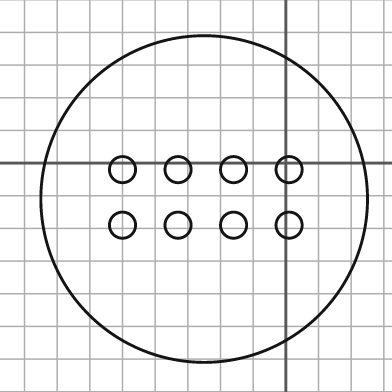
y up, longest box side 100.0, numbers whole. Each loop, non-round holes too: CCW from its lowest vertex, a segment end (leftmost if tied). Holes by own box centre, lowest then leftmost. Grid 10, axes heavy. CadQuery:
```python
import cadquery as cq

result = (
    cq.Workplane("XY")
    .moveTo(-25.0, -11.0)
    .circle(50.0)
    .moveTo(-50.0, -19.0)
    .circle(4.0)
    .moveTo(-33.0, -19.0)
    .circle(4.0)
    .moveTo(-16.0, -19.0)
    .circle(4.0)
    .moveTo(1.0, -19.0)
    .circle(4.0)
    .moveTo(-50.0, -2.0)
    .circle(4.0)
    .moveTo(-33.0, -2.0)
    .circle(4.0)
    .moveTo(-16.0, -2.0)
    .circle(4.0)
    .moveTo(1.0, -2.0)
    .circle(4.0)
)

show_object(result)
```